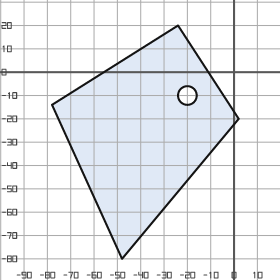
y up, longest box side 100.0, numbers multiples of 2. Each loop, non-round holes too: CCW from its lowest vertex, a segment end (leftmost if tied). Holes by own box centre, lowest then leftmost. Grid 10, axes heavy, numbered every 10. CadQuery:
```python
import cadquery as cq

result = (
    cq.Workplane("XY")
    .moveTo(-48.0, -80.0)
    .lineTo(2.0, -20.0)
    .lineTo(-24.0, 20.0)
    .lineTo(-78.0, -14.0)
    .close()
    .moveTo(-20.0, -10.0)
    .circle(4.0)
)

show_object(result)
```